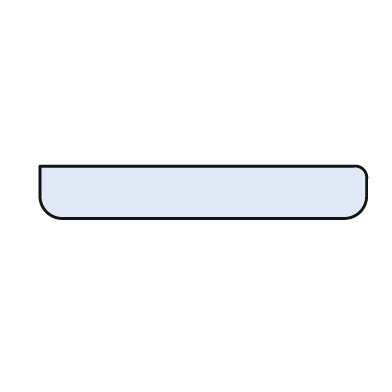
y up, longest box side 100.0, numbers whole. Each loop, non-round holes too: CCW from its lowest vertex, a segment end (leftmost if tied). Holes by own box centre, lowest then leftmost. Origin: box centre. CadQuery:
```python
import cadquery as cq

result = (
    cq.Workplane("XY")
    .moveTo(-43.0, -8.0)
    .lineTo(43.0, -8.0)
    .threePointArc((48.0, -6.0), (50.0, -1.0))
    .lineTo(50.0, 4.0)
    .threePointArc((49.0, 7.0), (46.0, 8.0))
    .lineTo(-50.0, 8.0)
    .lineTo(-50.0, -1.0)
    .threePointArc((-48.0, -6.0), (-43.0, -8.0))
    .close()
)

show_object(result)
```